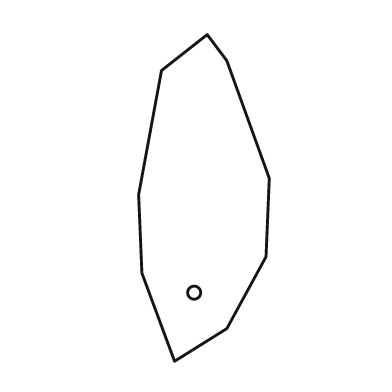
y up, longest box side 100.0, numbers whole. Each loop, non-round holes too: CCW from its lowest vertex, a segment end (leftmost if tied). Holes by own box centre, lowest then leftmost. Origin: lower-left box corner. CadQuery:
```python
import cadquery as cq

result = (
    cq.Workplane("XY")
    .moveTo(11.0, 0.0)
    .lineTo(27.0, 10.0)
    .lineTo(39.0, 32.0)
    .lineTo(40.0, 56.0)
    .lineTo(27.0, 92.0)
    .lineTo(21.0, 100.0)
    .lineTo(7.0, 89.0)
    .lineTo(0.0, 51.0)
    .lineTo(1.0, 27.0)
    .close()
    .moveTo(17.0, 21.0)
    .circle(2.0)
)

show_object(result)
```